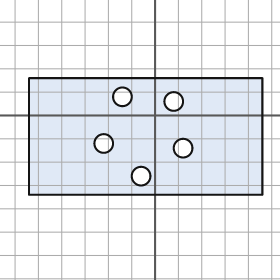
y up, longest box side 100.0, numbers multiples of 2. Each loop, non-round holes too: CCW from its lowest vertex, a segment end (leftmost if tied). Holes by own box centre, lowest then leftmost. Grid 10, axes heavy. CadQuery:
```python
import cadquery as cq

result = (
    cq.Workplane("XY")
    .moveTo(-54.0, -34.0)
    .lineTo(46.0, -34.0)
    .lineTo(46.0, 16.0)
    .lineTo(-54.0, 16.0)
    .close()
    .moveTo(-6.0, -26.0)
    .circle(4.0)
    .moveTo(12.0, -14.0)
    .circle(4.0)
    .moveTo(-22.0, -12.0)
    .circle(4.0)
    .moveTo(8.0, 6.0)
    .circle(4.0)
    .moveTo(-14.0, 8.0)
    .circle(4.0)
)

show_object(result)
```